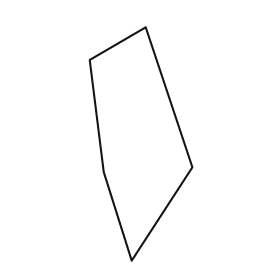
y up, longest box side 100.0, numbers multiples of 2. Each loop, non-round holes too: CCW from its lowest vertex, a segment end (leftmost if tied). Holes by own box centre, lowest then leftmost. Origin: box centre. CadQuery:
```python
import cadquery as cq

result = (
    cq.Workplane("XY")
    .moveTo(-4.0, -50.0)
    .lineTo(22.0, -10.0)
    .lineTo(2.0, 50.0)
    .lineTo(-22.0, 36.0)
    .lineTo(-16.0, -12.0)
    .close()
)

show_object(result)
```